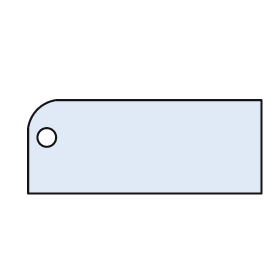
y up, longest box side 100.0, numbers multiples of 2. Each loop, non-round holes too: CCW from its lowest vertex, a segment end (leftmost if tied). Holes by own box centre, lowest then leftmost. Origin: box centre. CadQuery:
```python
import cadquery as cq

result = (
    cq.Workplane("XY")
    .moveTo(-50.0, -20.0)
    .lineTo(50.0, -20.0)
    .lineTo(50.0, 20.0)
    .lineTo(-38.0, 20.0)
    .threePointArc((-46.0, 16.0), (-50.0, 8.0))
    .close()
    .moveTo(-42.0, 4.0)
    .circle(4.0)
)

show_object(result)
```